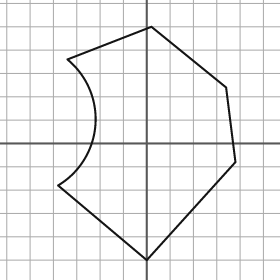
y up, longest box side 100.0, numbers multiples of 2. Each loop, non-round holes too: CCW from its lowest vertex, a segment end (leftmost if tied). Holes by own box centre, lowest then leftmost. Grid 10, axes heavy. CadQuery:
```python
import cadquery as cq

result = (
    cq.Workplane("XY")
    .moveTo(0.0, -50.0)
    .lineTo(38.0, -8.0)
    .lineTo(34.0, 24.0)
    .lineTo(2.0, 50.0)
    .lineTo(-34.0, 36.0)
    .threePointArc((-22.0, 8.0), (-38.0, -18.0))
    .close()
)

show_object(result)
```